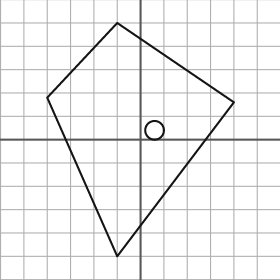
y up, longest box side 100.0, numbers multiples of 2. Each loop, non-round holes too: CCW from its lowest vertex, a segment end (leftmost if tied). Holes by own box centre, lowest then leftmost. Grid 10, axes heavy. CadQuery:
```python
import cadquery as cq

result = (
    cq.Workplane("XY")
    .moveTo(-10.0, -50.0)
    .lineTo(40.0, 16.0)
    .lineTo(-10.0, 50.0)
    .lineTo(-40.0, 18.0)
    .close()
    .moveTo(6.0, 4.0)
    .circle(4.0)
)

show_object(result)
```